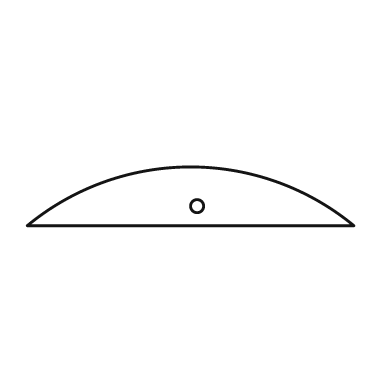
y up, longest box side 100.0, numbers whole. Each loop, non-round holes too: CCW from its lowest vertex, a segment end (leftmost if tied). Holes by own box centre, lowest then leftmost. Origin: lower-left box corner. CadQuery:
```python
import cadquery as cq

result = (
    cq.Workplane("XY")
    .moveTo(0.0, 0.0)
    .lineTo(100.0, 0.0)
    .threePointArc((50.0, 18.0), (0.0, 0.0))
    .close()
    .moveTo(52.0, 6.0)
    .circle(2.0)
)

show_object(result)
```